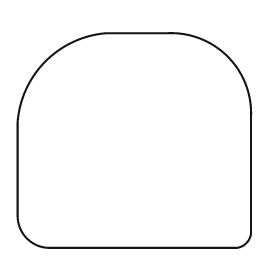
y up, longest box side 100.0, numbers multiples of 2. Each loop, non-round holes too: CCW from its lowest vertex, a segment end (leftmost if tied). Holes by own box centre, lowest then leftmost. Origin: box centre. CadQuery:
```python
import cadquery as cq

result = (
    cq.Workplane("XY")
    .moveTo(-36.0, -46.0)
    .lineTo(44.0, -46.0)
    .threePointArc((48.0, -44.0), (50.0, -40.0))
    .lineTo(50.0, 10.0)
    .threePointArc((40.0, 36.0), (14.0, 46.0))
    .lineTo(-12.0, 46.0)
    .threePointArc((-38.0, 34.0), (-50.0, 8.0))
    .lineTo(-50.0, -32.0)
    .threePointArc((-46.0, -42.0), (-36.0, -46.0))
    .close()
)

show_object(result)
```